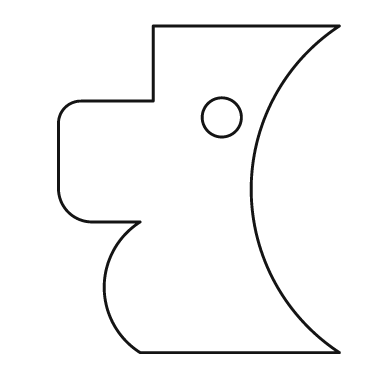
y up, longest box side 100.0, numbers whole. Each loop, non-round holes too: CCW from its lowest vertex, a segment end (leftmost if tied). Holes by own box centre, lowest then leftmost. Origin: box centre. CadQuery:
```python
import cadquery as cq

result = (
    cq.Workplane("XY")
    .moveTo(-18.0, -50.0)
    .lineTo(43.0, -50.0)
    .threePointArc((16.0, 0.0), (43.0, 50.0))
    .lineTo(-14.0, 50.0)
    .lineTo(-14.0, 27.0)
    .lineTo(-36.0, 27.0)
    .threePointArc((-41.0, 25.0), (-43.0, 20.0))
    .lineTo(-43.0, 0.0)
    .threePointArc((-40.0, -7.0), (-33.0, -10.0))
    .lineTo(-18.0, -10.0)
    .threePointArc((-29.0, -30.0), (-18.0, -50.0))
    .close()
    .moveTo(7.0, 22.0)
    .circle(6.0)
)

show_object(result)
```